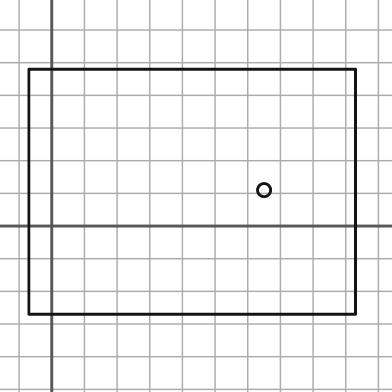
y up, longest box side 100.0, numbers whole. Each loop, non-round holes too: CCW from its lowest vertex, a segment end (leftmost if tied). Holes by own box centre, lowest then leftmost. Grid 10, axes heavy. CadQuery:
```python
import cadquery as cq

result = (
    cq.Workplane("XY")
    .moveTo(-7.0, -27.0)
    .lineTo(93.0, -27.0)
    .lineTo(93.0, 48.0)
    .lineTo(-7.0, 48.0)
    .close()
    .moveTo(65.0, 11.0)
    .circle(2.0)
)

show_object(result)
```